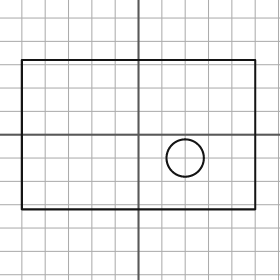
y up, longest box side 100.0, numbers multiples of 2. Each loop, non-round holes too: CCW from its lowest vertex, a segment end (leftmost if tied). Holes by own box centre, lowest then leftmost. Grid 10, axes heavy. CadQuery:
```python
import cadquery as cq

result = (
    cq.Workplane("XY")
    .moveTo(-50.0, -32.0)
    .lineTo(50.0, -32.0)
    .lineTo(50.0, 32.0)
    .lineTo(-50.0, 32.0)
    .close()
    .moveTo(20.0, -10.0)
    .circle(8.0)
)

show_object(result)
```